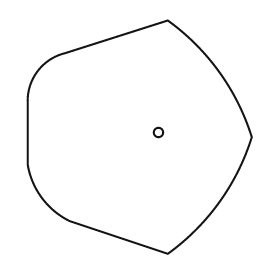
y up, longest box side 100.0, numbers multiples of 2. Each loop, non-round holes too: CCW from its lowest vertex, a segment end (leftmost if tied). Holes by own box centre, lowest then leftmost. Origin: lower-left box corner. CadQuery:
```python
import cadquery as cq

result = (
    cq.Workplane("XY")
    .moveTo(60.0, 0.0)
    .threePointArc((82.0, 22.0), (96.0, 50.0))
    .threePointArc((82.0, 78.0), (60.0, 100.0))
    .lineTo(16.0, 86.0)
    .threePointArc((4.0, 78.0), (0.0, 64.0))
    .lineTo(0.0, 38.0)
    .threePointArc((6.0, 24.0), (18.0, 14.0))
    .close()
    .moveTo(56.0, 52.0)
    .circle(2.0)
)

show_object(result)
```